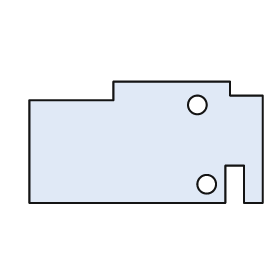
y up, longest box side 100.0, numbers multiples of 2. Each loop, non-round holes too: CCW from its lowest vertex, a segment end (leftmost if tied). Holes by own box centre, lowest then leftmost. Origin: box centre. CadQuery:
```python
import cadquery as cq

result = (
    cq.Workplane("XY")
    .moveTo(-50.0, -26.0)
    .lineTo(34.0, -26.0)
    .lineTo(34.0, -10.0)
    .lineTo(42.0, -10.0)
    .lineTo(42.0, -26.0)
    .lineTo(50.0, -26.0)
    .lineTo(50.0, 20.0)
    .lineTo(36.0, 20.0)
    .lineTo(36.0, 26.0)
    .lineTo(-14.0, 26.0)
    .lineTo(-14.0, 18.0)
    .lineTo(-50.0, 18.0)
    .close()
    .moveTo(26.0, -18.0)
    .circle(4.0)
    .moveTo(22.0, 16.0)
    .circle(4.0)
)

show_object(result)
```